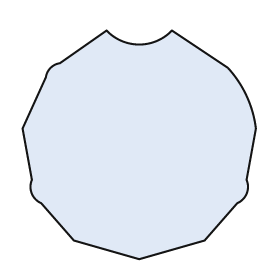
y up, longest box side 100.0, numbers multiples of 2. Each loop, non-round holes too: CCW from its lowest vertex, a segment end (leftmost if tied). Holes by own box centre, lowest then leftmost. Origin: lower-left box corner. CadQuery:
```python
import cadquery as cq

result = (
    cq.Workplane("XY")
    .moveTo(50.0, 0.0)
    .lineTo(78.0, 8.0)
    .lineTo(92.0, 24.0)
    .threePointArc((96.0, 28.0), (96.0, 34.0))
    .lineTo(100.0, 56.0)
    .threePointArc((96.0, 70.0), (88.0, 82.0))
    .lineTo(64.0, 98.0)
    .threePointArc((50.0, 92.0), (36.0, 98.0))
    .lineTo(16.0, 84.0)
    .threePointArc((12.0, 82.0), (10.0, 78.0))
    .lineTo(0.0, 56.0)
    .lineTo(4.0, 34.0)
    .threePointArc((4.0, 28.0), (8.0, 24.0))
    .lineTo(22.0, 8.0)
    .close()
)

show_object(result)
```